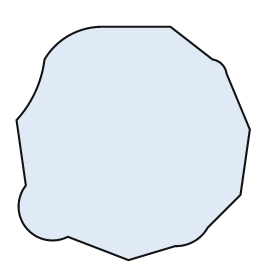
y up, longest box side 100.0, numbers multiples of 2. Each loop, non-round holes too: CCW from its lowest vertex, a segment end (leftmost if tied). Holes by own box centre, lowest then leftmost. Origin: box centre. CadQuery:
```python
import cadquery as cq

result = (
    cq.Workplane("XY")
    .moveTo(-2.0, -50.0)
    .lineTo(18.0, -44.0)
    .threePointArc((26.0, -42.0), (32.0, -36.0))
    .lineTo(46.0, -22.0)
    .lineTo(50.0, 6.0)
    .lineTo(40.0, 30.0)
    .threePointArc((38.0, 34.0), (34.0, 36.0))
    .lineTo(16.0, 50.0)
    .lineTo(-14.0, 50.0)
    .threePointArc((-28.0, 46.0), (-38.0, 36.0))
    .threePointArc((-42.0, 22.0), (-50.0, 10.0))
    .lineTo(-46.0, -18.0)
    .threePointArc((-46.0, -36.0), (-28.0, -40.0))
    .close()
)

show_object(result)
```